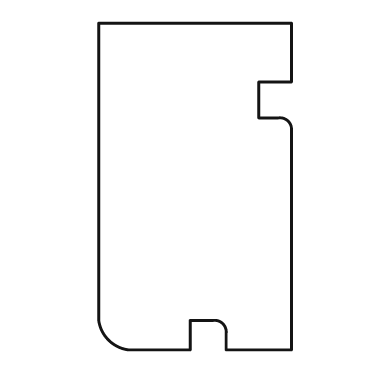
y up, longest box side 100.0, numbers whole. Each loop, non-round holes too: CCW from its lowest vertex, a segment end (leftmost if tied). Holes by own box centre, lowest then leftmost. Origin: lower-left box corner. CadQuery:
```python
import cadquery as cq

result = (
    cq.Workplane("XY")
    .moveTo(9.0, 0.0)
    .lineTo(28.0, 0.0)
    .lineTo(28.0, 9.0)
    .lineTo(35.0, 9.0)
    .threePointArc((38.0, 8.0), (39.0, 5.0))
    .lineTo(39.0, 0.0)
    .lineTo(59.0, 0.0)
    .lineTo(59.0, 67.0)
    .threePointArc((58.0, 70.0), (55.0, 71.0))
    .lineTo(49.0, 71.0)
    .lineTo(49.0, 82.0)
    .lineTo(59.0, 82.0)
    .lineTo(59.0, 100.0)
    .lineTo(0.0, 100.0)
    .lineTo(0.0, 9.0)
    .threePointArc((3.0, 3.0), (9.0, 0.0))
    .close()
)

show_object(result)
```